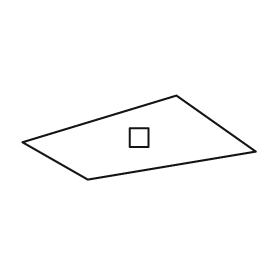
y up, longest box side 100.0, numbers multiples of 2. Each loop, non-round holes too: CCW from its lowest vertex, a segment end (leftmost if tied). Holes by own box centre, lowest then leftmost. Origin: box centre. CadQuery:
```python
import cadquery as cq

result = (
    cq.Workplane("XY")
    .moveTo(-22.0, -18.0)
    .lineTo(50.0, -6.0)
    .lineTo(16.0, 18.0)
    .lineTo(-50.0, -2.0)
    .close()
    .moveTo(-4.0, -4.0)
    .lineTo(4.0, -4.0)
    .lineTo(4.0, 4.0)
    .lineTo(-4.0, 4.0)
    .close()
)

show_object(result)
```